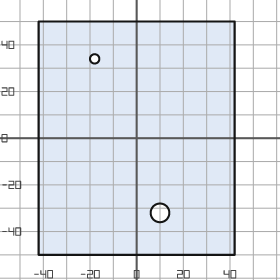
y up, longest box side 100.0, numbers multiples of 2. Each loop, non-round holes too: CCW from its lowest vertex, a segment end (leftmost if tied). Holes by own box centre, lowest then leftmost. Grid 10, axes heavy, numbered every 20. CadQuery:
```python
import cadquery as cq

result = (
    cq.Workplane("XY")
    .moveTo(-42.0, -50.0)
    .lineTo(42.0, -50.0)
    .lineTo(42.0, 50.0)
    .lineTo(-42.0, 50.0)
    .close()
    .moveTo(10.0, -32.0)
    .circle(4.0)
    .moveTo(-18.0, 34.0)
    .circle(2.0)
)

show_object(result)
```